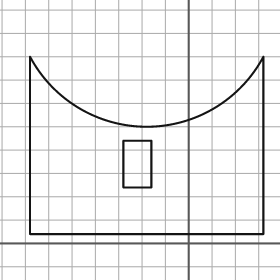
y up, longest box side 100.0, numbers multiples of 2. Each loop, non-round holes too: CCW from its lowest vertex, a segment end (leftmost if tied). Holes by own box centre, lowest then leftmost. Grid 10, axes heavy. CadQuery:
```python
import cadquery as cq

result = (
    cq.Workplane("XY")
    .moveTo(-68.0, 4.0)
    .lineTo(32.0, 4.0)
    .lineTo(32.0, 80.0)
    .threePointArc((-18.0, 50.0), (-68.0, 80.0))
    .close()
    .moveTo(-28.0, 24.0)
    .lineTo(-16.0, 24.0)
    .lineTo(-16.0, 44.0)
    .lineTo(-28.0, 44.0)
    .close()
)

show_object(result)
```